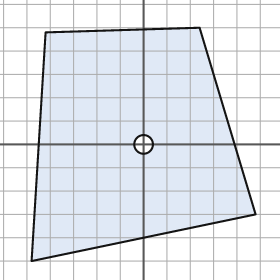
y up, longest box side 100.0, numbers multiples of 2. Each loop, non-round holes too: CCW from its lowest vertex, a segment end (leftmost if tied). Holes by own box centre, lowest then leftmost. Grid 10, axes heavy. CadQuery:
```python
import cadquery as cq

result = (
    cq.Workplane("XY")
    .moveTo(-48.0, -50.0)
    .lineTo(48.0, -30.0)
    .lineTo(24.0, 50.0)
    .lineTo(-42.0, 48.0)
    .close()
    .moveTo(0.0, 0.0)
    .circle(4.0)
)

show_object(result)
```